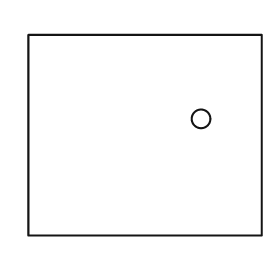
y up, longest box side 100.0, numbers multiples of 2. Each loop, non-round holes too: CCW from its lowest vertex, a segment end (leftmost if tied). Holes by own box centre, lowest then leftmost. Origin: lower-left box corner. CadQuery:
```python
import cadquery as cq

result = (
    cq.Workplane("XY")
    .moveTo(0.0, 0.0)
    .lineTo(100.0, 0.0)
    .lineTo(100.0, 86.0)
    .lineTo(0.0, 86.0)
    .close()
    .moveTo(74.0, 50.0)
    .circle(4.0)
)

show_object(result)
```